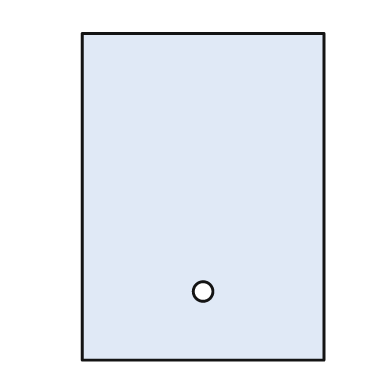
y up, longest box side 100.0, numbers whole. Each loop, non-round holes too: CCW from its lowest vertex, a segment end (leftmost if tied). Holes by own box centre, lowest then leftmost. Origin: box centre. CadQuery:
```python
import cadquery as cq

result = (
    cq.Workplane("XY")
    .moveTo(-37.0, -50.0)
    .lineTo(37.0, -50.0)
    .lineTo(37.0, 50.0)
    .lineTo(-37.0, 50.0)
    .close()
    .moveTo(0.0, -29.0)
    .circle(3.0)
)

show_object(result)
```